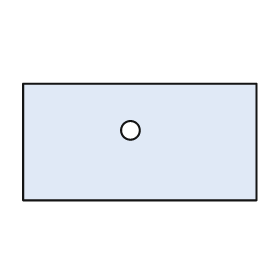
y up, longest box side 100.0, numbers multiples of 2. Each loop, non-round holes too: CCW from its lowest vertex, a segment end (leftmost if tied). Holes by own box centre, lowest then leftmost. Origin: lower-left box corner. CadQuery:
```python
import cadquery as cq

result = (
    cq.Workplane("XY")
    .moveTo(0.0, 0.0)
    .lineTo(100.0, 0.0)
    .lineTo(100.0, 50.0)
    .lineTo(0.0, 50.0)
    .close()
    .moveTo(46.0, 30.0)
    .circle(4.0)
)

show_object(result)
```